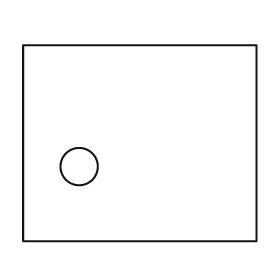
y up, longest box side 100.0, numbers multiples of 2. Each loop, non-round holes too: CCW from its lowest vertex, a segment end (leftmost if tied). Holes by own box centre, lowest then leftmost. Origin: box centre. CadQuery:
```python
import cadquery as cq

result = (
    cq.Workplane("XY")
    .moveTo(-50.0, -42.0)
    .lineTo(50.0, -42.0)
    .lineTo(50.0, 42.0)
    .lineTo(-50.0, 42.0)
    .close()
    .moveTo(-26.0, -10.0)
    .circle(8.0)
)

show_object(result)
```